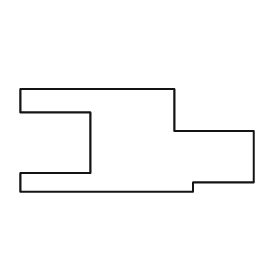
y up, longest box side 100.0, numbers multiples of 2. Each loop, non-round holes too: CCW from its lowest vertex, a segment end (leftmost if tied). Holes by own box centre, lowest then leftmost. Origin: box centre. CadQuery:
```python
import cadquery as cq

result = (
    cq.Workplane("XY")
    .moveTo(-50.0, -22.0)
    .lineTo(24.0, -22.0)
    .lineTo(24.0, -18.0)
    .lineTo(50.0, -18.0)
    .lineTo(50.0, 4.0)
    .lineTo(16.0, 4.0)
    .lineTo(16.0, 22.0)
    .lineTo(-50.0, 22.0)
    .lineTo(-50.0, 12.0)
    .lineTo(-20.0, 12.0)
    .lineTo(-20.0, -14.0)
    .lineTo(-50.0, -14.0)
    .close()
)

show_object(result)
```